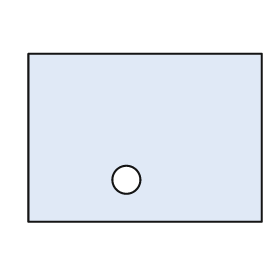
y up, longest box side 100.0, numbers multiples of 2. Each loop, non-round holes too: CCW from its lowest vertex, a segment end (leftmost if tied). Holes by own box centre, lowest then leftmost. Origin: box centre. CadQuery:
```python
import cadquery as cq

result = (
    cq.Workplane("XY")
    .moveTo(-50.0, -36.0)
    .lineTo(50.0, -36.0)
    .lineTo(50.0, 36.0)
    .lineTo(-50.0, 36.0)
    .close()
    .moveTo(-8.0, -18.0)
    .circle(6.0)
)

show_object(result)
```